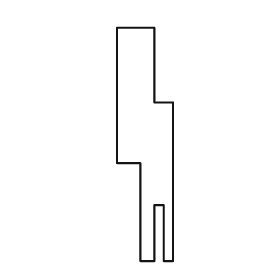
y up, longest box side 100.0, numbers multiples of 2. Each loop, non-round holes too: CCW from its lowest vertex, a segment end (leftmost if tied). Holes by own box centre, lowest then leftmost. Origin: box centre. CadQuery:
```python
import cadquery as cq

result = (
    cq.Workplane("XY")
    .moveTo(-2.0, -50.0)
    .lineTo(4.0, -50.0)
    .lineTo(4.0, -26.0)
    .lineTo(8.0, -26.0)
    .lineTo(8.0, -50.0)
    .lineTo(12.0, -50.0)
    .lineTo(12.0, 18.0)
    .lineTo(4.0, 18.0)
    .lineTo(4.0, 50.0)
    .lineTo(-12.0, 50.0)
    .lineTo(-12.0, -8.0)
    .lineTo(-2.0, -8.0)
    .close()
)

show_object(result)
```